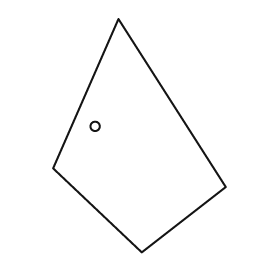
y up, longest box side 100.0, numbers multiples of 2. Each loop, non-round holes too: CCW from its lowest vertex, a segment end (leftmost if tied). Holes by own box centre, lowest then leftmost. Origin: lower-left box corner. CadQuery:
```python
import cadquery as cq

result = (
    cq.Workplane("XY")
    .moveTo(38.0, 0.0)
    .lineTo(74.0, 28.0)
    .lineTo(28.0, 100.0)
    .lineTo(0.0, 36.0)
    .close()
    .moveTo(18.0, 54.0)
    .circle(2.0)
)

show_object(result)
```